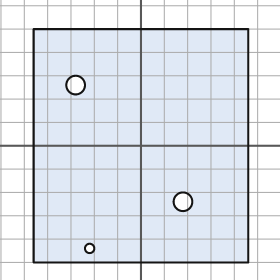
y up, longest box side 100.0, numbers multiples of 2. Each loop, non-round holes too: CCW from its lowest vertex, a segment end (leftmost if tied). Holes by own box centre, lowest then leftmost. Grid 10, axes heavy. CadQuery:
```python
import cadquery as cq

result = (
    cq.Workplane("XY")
    .moveTo(-46.0, -50.0)
    .lineTo(46.0, -50.0)
    .lineTo(46.0, 50.0)
    .lineTo(-46.0, 50.0)
    .close()
    .moveTo(-22.0, -44.0)
    .circle(2.0)
    .moveTo(18.0, -24.0)
    .circle(4.0)
    .moveTo(-28.0, 26.0)
    .circle(4.0)
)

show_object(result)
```